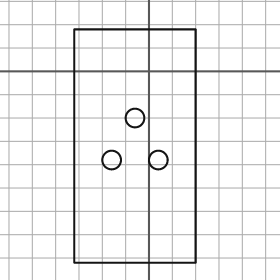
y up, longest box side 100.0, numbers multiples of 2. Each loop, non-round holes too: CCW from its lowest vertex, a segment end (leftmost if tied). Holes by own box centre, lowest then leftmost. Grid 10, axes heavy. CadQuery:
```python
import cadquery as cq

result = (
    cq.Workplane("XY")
    .moveTo(-32.0, -82.0)
    .lineTo(20.0, -82.0)
    .lineTo(20.0, 18.0)
    .lineTo(-32.0, 18.0)
    .close()
    .moveTo(-16.0, -38.0)
    .circle(4.0)
    .moveTo(4.0, -38.0)
    .circle(4.0)
    .moveTo(-6.0, -20.0)
    .circle(4.0)
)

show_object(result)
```